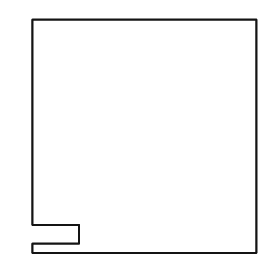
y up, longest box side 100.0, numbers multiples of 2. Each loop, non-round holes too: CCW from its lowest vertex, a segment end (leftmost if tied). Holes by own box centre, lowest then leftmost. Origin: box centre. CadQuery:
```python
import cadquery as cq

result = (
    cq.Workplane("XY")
    .moveTo(-48.0, -50.0)
    .lineTo(48.0, -50.0)
    .lineTo(48.0, 50.0)
    .lineTo(-48.0, 50.0)
    .lineTo(-48.0, -38.0)
    .lineTo(-28.0, -38.0)
    .lineTo(-28.0, -46.0)
    .lineTo(-48.0, -46.0)
    .close()
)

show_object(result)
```